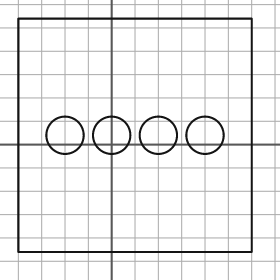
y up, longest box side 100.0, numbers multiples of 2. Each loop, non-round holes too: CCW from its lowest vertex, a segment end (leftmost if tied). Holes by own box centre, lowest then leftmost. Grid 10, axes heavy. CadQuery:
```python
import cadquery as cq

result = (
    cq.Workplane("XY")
    .moveTo(-40.0, -46.0)
    .lineTo(60.0, -46.0)
    .lineTo(60.0, 54.0)
    .lineTo(-40.0, 54.0)
    .close()
    .moveTo(-20.0, 4.0)
    .circle(8.0)
    .moveTo(0.0, 4.0)
    .circle(8.0)
    .moveTo(20.0, 4.0)
    .circle(8.0)
    .moveTo(40.0, 4.0)
    .circle(8.0)
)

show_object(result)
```